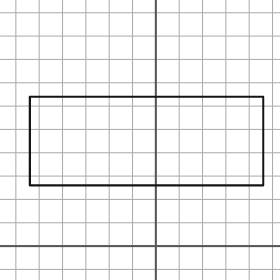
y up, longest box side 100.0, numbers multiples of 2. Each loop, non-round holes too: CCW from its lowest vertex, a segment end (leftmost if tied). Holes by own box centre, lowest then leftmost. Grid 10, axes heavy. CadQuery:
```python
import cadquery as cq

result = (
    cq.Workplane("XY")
    .moveTo(-54.0, 26.0)
    .lineTo(46.0, 26.0)
    .lineTo(46.0, 64.0)
    .lineTo(-54.0, 64.0)
    .close()
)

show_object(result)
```